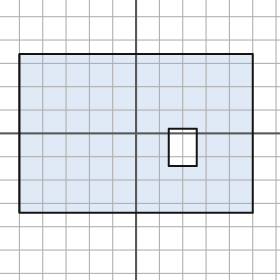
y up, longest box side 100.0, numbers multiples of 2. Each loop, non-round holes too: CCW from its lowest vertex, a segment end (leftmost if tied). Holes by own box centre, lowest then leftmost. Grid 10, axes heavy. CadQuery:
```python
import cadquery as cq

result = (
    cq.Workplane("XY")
    .moveTo(-50.0, -34.0)
    .lineTo(50.0, -34.0)
    .lineTo(50.0, 34.0)
    .lineTo(-50.0, 34.0)
    .close()
    .moveTo(14.0, -14.0)
    .lineTo(26.0, -14.0)
    .lineTo(26.0, 2.0)
    .lineTo(14.0, 2.0)
    .close()
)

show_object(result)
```